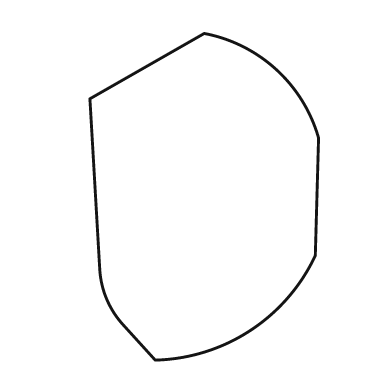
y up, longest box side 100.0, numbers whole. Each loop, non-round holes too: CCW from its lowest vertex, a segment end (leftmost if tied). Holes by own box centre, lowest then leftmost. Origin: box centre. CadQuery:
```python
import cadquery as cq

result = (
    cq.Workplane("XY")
    .moveTo(-15.0, -50.0)
    .threePointArc((14.0, -41.0), (34.0, -18.0))
    .lineTo(35.0, 18.0)
    .threePointArc((22.0, 39.0), (0.0, 50.0))
    .lineTo(-35.0, 30.0)
    .lineTo(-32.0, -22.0)
    .threePointArc((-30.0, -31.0), (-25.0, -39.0))
    .close()
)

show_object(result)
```